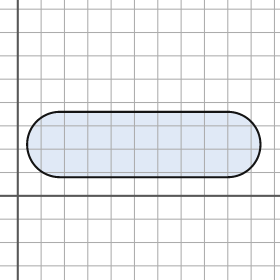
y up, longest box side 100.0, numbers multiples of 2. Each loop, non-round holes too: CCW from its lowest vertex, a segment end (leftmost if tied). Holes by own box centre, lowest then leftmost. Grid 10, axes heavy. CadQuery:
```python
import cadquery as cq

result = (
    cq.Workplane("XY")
    .moveTo(18.0, 8.0)
    .lineTo(90.0, 8.0)
    .threePointArc((104.0, 22.0), (90.0, 36.0))
    .lineTo(18.0, 36.0)
    .threePointArc((4.0, 22.0), (18.0, 8.0))
    .close()
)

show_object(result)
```